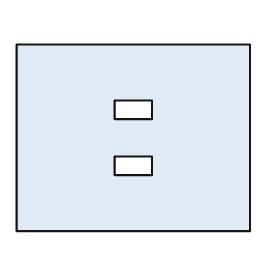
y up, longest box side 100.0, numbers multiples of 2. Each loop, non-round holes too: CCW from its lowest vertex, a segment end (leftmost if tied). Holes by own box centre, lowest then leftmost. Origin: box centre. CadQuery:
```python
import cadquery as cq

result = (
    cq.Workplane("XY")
    .moveTo(-50.0, -40.0)
    .lineTo(50.0, -40.0)
    .lineTo(50.0, 40.0)
    .lineTo(-50.0, 40.0)
    .close()
    .moveTo(-8.0, -16.0)
    .lineTo(8.0, -16.0)
    .lineTo(8.0, -8.0)
    .lineTo(-8.0, -8.0)
    .close()
    .moveTo(-8.0, 8.0)
    .lineTo(8.0, 8.0)
    .lineTo(8.0, 16.0)
    .lineTo(-8.0, 16.0)
    .close()
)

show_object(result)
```